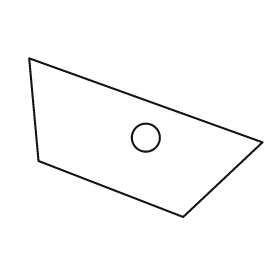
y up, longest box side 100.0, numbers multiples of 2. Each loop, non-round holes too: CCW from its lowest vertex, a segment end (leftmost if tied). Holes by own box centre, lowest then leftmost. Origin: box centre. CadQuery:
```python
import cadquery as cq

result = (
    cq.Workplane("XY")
    .moveTo(16.0, -34.0)
    .lineTo(50.0, -2.0)
    .lineTo(-50.0, 34.0)
    .lineTo(-46.0, -10.0)
    .close()
    .moveTo(0.0, 0.0)
    .circle(6.0)
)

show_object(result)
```